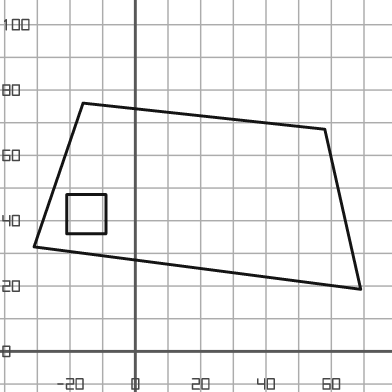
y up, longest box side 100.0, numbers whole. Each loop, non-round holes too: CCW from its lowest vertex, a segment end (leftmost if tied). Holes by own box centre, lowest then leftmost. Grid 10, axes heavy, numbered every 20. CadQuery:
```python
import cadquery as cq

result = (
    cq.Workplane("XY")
    .moveTo(69.0, 19.0)
    .lineTo(58.0, 68.0)
    .lineTo(-16.0, 76.0)
    .lineTo(-31.0, 32.0)
    .close()
    .moveTo(-21.0, 36.0)
    .lineTo(-9.0, 36.0)
    .lineTo(-9.0, 48.0)
    .lineTo(-21.0, 48.0)
    .close()
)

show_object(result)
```